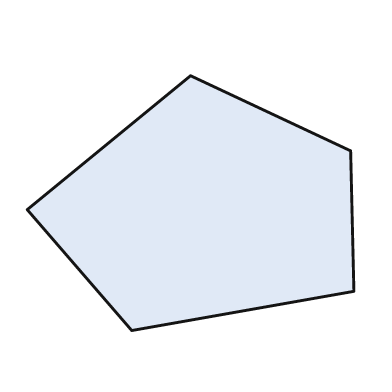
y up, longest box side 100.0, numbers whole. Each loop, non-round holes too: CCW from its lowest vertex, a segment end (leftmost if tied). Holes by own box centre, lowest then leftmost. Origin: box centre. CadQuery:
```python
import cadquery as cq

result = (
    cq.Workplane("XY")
    .moveTo(-18.0, -39.0)
    .lineTo(50.0, -27.0)
    .lineTo(49.0, 16.0)
    .lineTo(0.0, 39.0)
    .lineTo(-50.0, -2.0)
    .close()
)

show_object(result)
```